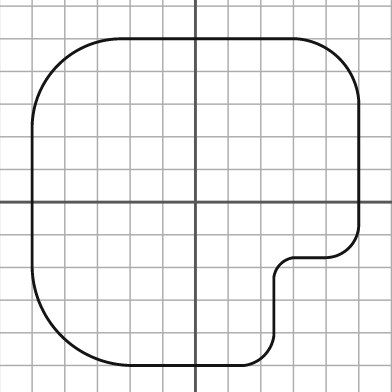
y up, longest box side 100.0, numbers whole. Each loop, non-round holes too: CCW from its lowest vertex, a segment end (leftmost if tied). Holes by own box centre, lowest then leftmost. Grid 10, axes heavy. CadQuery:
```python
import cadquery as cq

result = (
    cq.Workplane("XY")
    .moveTo(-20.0, -50.0)
    .lineTo(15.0, -50.0)
    .threePointArc((21.0, -47.0), (24.0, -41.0))
    .lineTo(24.0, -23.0)
    .threePointArc((26.0, -19.0), (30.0, -17.0))
    .lineTo(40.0, -17.0)
    .threePointArc((47.0, -14.0), (50.0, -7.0))
    .lineTo(50.0, 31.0)
    .threePointArc((44.0, 44.0), (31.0, 50.0))
    .lineTo(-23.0, 50.0)
    .threePointArc((-42.0, 42.0), (-50.0, 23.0))
    .lineTo(-50.0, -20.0)
    .threePointArc((-41.0, -41.0), (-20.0, -50.0))
    .close()
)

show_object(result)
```